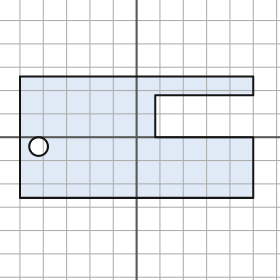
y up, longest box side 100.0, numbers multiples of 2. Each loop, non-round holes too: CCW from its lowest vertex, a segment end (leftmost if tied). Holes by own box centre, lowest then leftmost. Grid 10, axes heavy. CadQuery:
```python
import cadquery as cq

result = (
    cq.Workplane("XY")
    .moveTo(-50.0, -26.0)
    .lineTo(50.0, -26.0)
    .lineTo(50.0, 0.0)
    .lineTo(8.0, 0.0)
    .lineTo(8.0, 18.0)
    .lineTo(50.0, 18.0)
    .lineTo(50.0, 26.0)
    .lineTo(-50.0, 26.0)
    .close()
    .moveTo(-42.0, -4.0)
    .circle(4.0)
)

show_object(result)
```